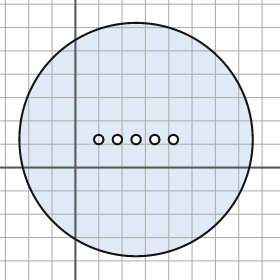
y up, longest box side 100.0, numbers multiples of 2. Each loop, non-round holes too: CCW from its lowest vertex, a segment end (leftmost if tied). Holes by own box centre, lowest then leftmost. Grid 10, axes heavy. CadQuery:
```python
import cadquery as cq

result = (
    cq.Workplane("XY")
    .moveTo(26.0, 12.0)
    .circle(50.0)
    .moveTo(10.0, 12.0)
    .circle(2.0)
    .moveTo(18.0, 12.0)
    .circle(2.0)
    .moveTo(26.0, 12.0)
    .circle(2.0)
    .moveTo(34.0, 12.0)
    .circle(2.0)
    .moveTo(42.0, 12.0)
    .circle(2.0)
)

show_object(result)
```